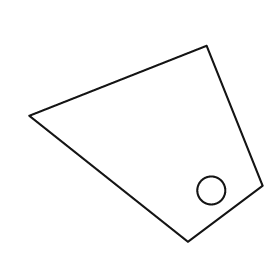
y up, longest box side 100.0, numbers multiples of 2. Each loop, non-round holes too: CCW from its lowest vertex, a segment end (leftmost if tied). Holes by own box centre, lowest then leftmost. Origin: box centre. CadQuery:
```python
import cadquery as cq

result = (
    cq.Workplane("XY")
    .moveTo(18.0, -42.0)
    .lineTo(50.0, -18.0)
    .lineTo(26.0, 42.0)
    .lineTo(-50.0, 12.0)
    .close()
    .moveTo(28.0, -20.0)
    .circle(6.0)
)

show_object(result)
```